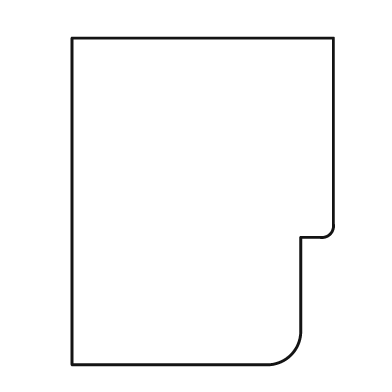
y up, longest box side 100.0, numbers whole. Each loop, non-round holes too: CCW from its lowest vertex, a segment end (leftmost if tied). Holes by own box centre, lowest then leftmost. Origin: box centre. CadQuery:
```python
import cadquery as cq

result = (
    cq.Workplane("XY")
    .moveTo(-40.0, -50.0)
    .lineTo(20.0, -50.0)
    .threePointArc((27.0, -47.0), (30.0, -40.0))
    .lineTo(30.0, -11.0)
    .lineTo(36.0, -11.0)
    .threePointArc((39.0, -10.0), (40.0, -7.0))
    .lineTo(40.0, 50.0)
    .lineTo(-40.0, 50.0)
    .close()
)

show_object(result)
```